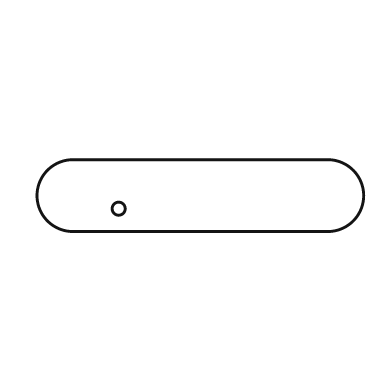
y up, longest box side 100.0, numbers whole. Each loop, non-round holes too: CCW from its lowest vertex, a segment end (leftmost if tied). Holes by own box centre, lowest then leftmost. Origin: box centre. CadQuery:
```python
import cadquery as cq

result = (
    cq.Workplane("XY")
    .moveTo(-39.0, -11.0)
    .lineTo(39.0, -11.0)
    .threePointArc((50.0, 0.0), (39.0, 11.0))
    .lineTo(-39.0, 11.0)
    .threePointArc((-50.0, 0.0), (-39.0, -11.0))
    .close()
    .moveTo(-25.0, -4.0)
    .circle(2.0)
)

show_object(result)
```